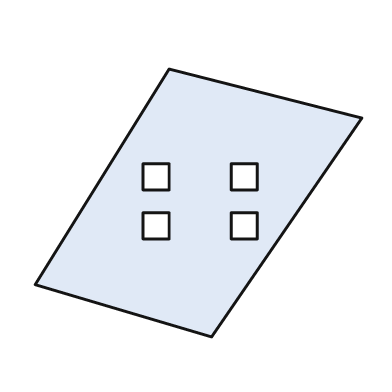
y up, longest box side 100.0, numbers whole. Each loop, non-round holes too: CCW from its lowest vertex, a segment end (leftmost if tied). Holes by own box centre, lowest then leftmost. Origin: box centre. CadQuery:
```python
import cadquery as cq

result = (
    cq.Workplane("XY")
    .moveTo(4.0, -41.0)
    .lineTo(50.0, 26.0)
    .lineTo(-9.0, 41.0)
    .lineTo(-50.0, -25.0)
    .close()
    .moveTo(-17.0, -11.0)
    .lineTo(-9.0, -11.0)
    .lineTo(-9.0, -3.0)
    .lineTo(-17.0, -3.0)
    .close()
    .moveTo(10.0, -11.0)
    .lineTo(18.0, -11.0)
    .lineTo(18.0, -3.0)
    .lineTo(10.0, -3.0)
    .close()
    .moveTo(-17.0, 4.0)
    .lineTo(-9.0, 4.0)
    .lineTo(-9.0, 12.0)
    .lineTo(-17.0, 12.0)
    .close()
    .moveTo(10.0, 4.0)
    .lineTo(18.0, 4.0)
    .lineTo(18.0, 12.0)
    .lineTo(10.0, 12.0)
    .close()
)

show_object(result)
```